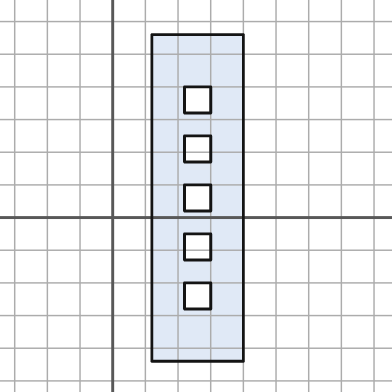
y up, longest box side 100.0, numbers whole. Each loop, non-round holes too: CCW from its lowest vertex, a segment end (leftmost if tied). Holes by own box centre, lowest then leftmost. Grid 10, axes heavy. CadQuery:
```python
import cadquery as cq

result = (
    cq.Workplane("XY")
    .moveTo(12.0, -44.0)
    .lineTo(40.0, -44.0)
    .lineTo(40.0, 56.0)
    .lineTo(12.0, 56.0)
    .close()
    .moveTo(22.0, -28.0)
    .lineTo(30.0, -28.0)
    .lineTo(30.0, -20.0)
    .lineTo(22.0, -20.0)
    .close()
    .moveTo(22.0, -13.0)
    .lineTo(30.0, -13.0)
    .lineTo(30.0, -5.0)
    .lineTo(22.0, -5.0)
    .close()
    .moveTo(22.0, 2.0)
    .lineTo(30.0, 2.0)
    .lineTo(30.0, 10.0)
    .lineTo(22.0, 10.0)
    .close()
    .moveTo(22.0, 17.0)
    .lineTo(30.0, 17.0)
    .lineTo(30.0, 25.0)
    .lineTo(22.0, 25.0)
    .close()
    .moveTo(22.0, 32.0)
    .lineTo(30.0, 32.0)
    .lineTo(30.0, 40.0)
    .lineTo(22.0, 40.0)
    .close()
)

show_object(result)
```